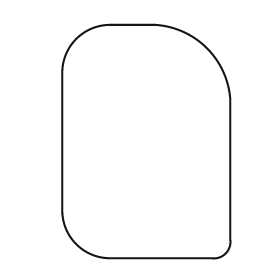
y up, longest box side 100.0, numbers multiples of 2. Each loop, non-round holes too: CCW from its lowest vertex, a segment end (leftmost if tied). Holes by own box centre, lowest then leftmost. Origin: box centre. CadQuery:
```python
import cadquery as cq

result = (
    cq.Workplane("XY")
    .moveTo(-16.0, -50.0)
    .lineTo(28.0, -50.0)
    .threePointArc((34.0, -48.0), (36.0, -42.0))
    .lineTo(36.0, 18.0)
    .threePointArc((26.0, 40.0), (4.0, 50.0))
    .lineTo(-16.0, 50.0)
    .threePointArc((-30.0, 44.0), (-36.0, 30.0))
    .lineTo(-36.0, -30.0)
    .threePointArc((-30.0, -44.0), (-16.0, -50.0))
    .close()
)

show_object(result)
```